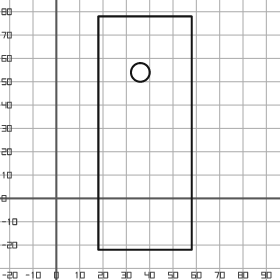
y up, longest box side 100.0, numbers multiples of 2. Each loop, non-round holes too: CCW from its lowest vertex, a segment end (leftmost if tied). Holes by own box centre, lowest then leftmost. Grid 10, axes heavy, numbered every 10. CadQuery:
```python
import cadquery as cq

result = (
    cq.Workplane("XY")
    .moveTo(18.0, -22.0)
    .lineTo(58.0, -22.0)
    .lineTo(58.0, 78.0)
    .lineTo(18.0, 78.0)
    .close()
    .moveTo(36.0, 54.0)
    .circle(4.0)
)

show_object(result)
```